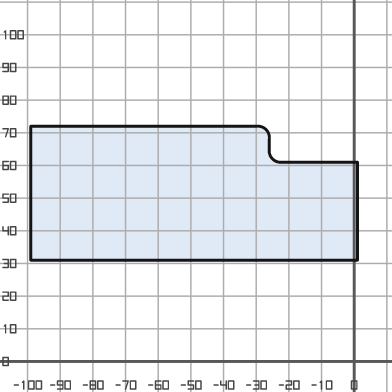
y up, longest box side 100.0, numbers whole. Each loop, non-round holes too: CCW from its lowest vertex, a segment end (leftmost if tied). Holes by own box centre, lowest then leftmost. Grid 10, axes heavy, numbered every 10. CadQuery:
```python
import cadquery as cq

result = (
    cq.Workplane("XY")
    .moveTo(-99.0, 31.0)
    .lineTo(1.0, 31.0)
    .lineTo(1.0, 61.0)
    .lineTo(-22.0, 61.0)
    .threePointArc((-25.0, 62.0), (-26.0, 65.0))
    .lineTo(-26.0, 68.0)
    .threePointArc((-27.0, 71.0), (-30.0, 72.0))
    .lineTo(-99.0, 72.0)
    .close()
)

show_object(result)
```